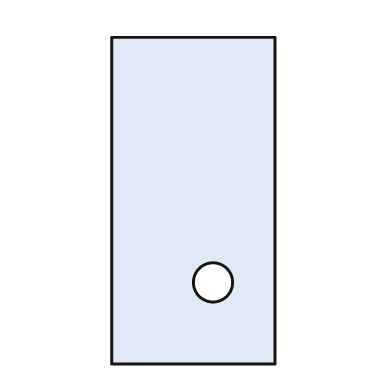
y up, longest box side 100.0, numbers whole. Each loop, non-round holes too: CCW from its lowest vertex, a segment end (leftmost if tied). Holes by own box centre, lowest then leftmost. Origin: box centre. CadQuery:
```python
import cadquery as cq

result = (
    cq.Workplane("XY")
    .moveTo(-25.0, -50.0)
    .lineTo(25.0, -50.0)
    .lineTo(25.0, 50.0)
    .lineTo(-25.0, 50.0)
    .close()
    .moveTo(6.0, -25.0)
    .circle(6.0)
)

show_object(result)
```